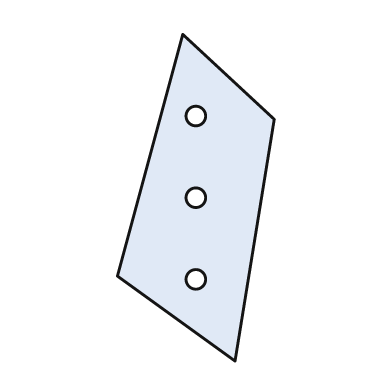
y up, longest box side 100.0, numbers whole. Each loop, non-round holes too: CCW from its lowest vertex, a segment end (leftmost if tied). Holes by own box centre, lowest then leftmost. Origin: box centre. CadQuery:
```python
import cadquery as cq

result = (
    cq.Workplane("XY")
    .moveTo(12.0, -50.0)
    .lineTo(24.0, 24.0)
    .lineTo(-4.0, 50.0)
    .lineTo(-24.0, -24.0)
    .close()
    .moveTo(0.0, -25.0)
    .circle(3.0)
    .moveTo(0.0, 0.0)
    .circle(3.0)
    .moveTo(0.0, 25.0)
    .circle(3.0)
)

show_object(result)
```